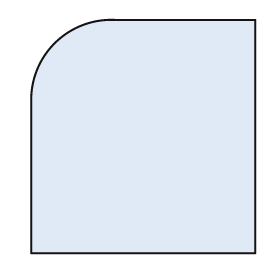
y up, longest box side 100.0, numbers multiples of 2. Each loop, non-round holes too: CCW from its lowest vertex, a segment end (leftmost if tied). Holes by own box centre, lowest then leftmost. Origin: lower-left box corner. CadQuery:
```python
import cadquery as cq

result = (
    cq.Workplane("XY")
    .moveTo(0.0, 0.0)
    .lineTo(96.0, 0.0)
    .lineTo(96.0, 100.0)
    .lineTo(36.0, 100.0)
    .threePointArc((10.0, 90.0), (0.0, 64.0))
    .close()
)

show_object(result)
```